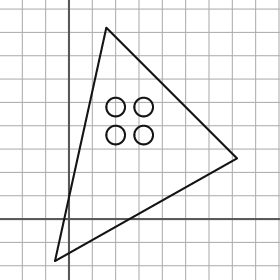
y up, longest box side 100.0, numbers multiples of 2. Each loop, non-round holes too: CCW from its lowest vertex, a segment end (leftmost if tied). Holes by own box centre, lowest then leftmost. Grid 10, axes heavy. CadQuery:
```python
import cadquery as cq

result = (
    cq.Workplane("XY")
    .moveTo(-6.0, -18.0)
    .lineTo(72.0, 26.0)
    .lineTo(16.0, 82.0)
    .close()
    .moveTo(20.0, 36.0)
    .circle(4.0)
    .moveTo(32.0, 36.0)
    .circle(4.0)
    .moveTo(20.0, 48.0)
    .circle(4.0)
    .moveTo(32.0, 48.0)
    .circle(4.0)
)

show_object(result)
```